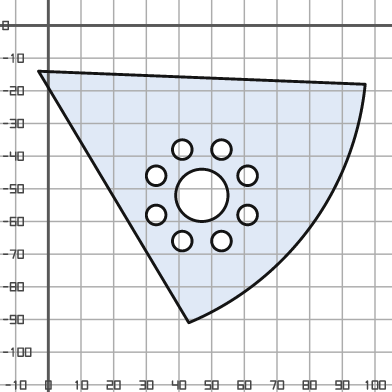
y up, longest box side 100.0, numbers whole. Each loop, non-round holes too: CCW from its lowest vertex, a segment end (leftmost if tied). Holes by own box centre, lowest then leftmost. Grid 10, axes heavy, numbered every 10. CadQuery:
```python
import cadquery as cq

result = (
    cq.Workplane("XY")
    .moveTo(43.0, -91.0)
    .threePointArc((80.0, -62.0), (97.0, -18.0))
    .lineTo(-3.0, -14.0)
    .close()
    .moveTo(41.0, -66.0)
    .circle(3.0)
    .moveTo(53.0, -66.0)
    .circle(3.0)
    .moveTo(33.0, -58.0)
    .circle(3.0)
    .moveTo(61.0, -58.0)
    .circle(3.0)
    .moveTo(47.0, -52.0)
    .circle(8.0)
    .moveTo(33.0, -46.0)
    .circle(3.0)
    .moveTo(61.0, -46.0)
    .circle(3.0)
    .moveTo(41.0, -38.0)
    .circle(3.0)
    .moveTo(53.0, -38.0)
    .circle(3.0)
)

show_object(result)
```